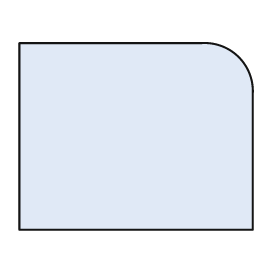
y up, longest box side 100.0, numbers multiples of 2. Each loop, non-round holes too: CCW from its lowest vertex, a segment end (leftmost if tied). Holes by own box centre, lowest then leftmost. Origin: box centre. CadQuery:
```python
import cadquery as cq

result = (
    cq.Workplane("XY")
    .moveTo(-50.0, -40.0)
    .lineTo(50.0, -40.0)
    .lineTo(50.0, 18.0)
    .threePointArc((44.0, 34.0), (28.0, 40.0))
    .lineTo(-50.0, 40.0)
    .close()
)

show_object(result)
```